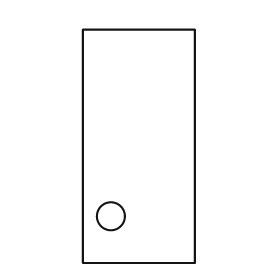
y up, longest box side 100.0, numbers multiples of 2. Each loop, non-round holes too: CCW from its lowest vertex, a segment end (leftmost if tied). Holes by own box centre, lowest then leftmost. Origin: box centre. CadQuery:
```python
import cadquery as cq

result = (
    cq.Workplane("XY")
    .moveTo(-24.0, -50.0)
    .lineTo(24.0, -50.0)
    .lineTo(24.0, 50.0)
    .lineTo(-24.0, 50.0)
    .close()
    .moveTo(-12.0, -30.0)
    .circle(6.0)
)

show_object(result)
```